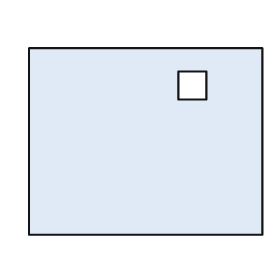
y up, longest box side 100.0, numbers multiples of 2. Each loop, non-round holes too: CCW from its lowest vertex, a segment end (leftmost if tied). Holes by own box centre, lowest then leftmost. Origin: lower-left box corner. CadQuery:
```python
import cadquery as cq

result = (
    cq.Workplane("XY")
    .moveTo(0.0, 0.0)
    .lineTo(100.0, 0.0)
    .lineTo(100.0, 80.0)
    .lineTo(0.0, 80.0)
    .close()
    .moveTo(64.0, 58.0)
    .lineTo(76.0, 58.0)
    .lineTo(76.0, 70.0)
    .lineTo(64.0, 70.0)
    .close()
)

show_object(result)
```